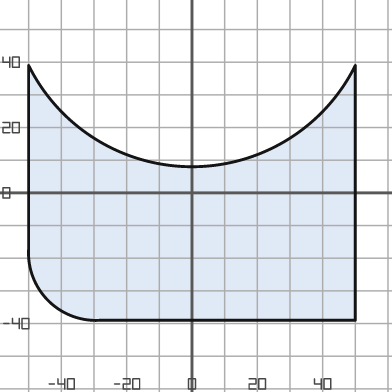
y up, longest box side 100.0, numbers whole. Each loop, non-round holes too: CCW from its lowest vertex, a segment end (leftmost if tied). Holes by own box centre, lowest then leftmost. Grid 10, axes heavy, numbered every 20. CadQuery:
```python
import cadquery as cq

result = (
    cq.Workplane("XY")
    .moveTo(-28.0, -39.0)
    .lineTo(50.0, -39.0)
    .lineTo(50.0, 39.0)
    .threePointArc((0.0, 8.0), (-50.0, 39.0))
    .lineTo(-50.0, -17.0)
    .threePointArc((-44.0, -33.0), (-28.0, -39.0))
    .close()
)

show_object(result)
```